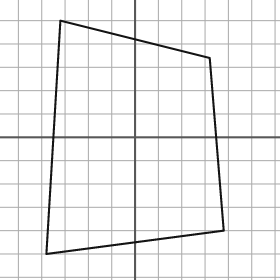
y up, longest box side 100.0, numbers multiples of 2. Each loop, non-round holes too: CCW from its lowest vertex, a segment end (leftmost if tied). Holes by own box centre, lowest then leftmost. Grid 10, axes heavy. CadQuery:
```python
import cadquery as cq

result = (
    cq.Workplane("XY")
    .moveTo(-38.0, -50.0)
    .lineTo(38.0, -40.0)
    .lineTo(32.0, 34.0)
    .lineTo(-32.0, 50.0)
    .close()
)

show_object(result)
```